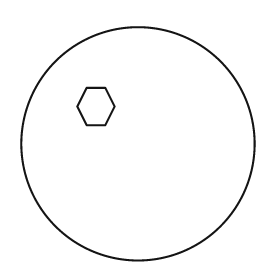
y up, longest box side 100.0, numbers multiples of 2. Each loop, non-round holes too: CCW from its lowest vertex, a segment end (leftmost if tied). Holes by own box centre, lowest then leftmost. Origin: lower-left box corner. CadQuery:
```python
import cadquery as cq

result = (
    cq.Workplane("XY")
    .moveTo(50.0, 50.0)
    .circle(50.0)
    .moveTo(28.0, 58.0)
    .lineTo(36.0, 58.0)
    .lineTo(40.0, 66.0)
    .lineTo(36.0, 74.0)
    .lineTo(28.0, 74.0)
    .lineTo(24.0, 66.0)
    .close()
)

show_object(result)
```